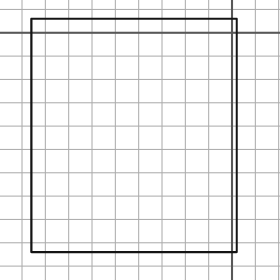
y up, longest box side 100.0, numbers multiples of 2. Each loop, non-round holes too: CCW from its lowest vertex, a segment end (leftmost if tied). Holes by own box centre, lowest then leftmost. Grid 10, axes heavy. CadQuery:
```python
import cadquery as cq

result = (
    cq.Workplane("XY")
    .moveTo(-86.0, -94.0)
    .lineTo(2.0, -94.0)
    .lineTo(2.0, 6.0)
    .lineTo(-86.0, 6.0)
    .close()
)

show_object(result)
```